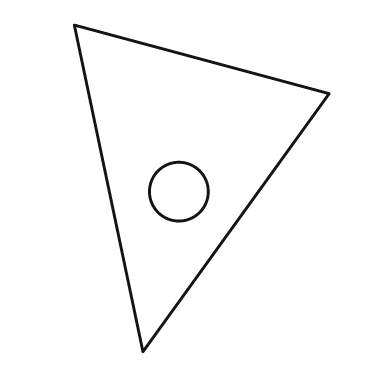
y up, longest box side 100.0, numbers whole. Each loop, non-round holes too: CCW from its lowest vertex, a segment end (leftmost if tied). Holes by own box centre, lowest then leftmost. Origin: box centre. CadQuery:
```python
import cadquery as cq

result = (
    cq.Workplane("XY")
    .moveTo(-18.0, -50.0)
    .lineTo(39.0, 29.0)
    .lineTo(-39.0, 50.0)
    .close()
    .moveTo(-7.0, -1.0)
    .circle(9.0)
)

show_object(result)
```